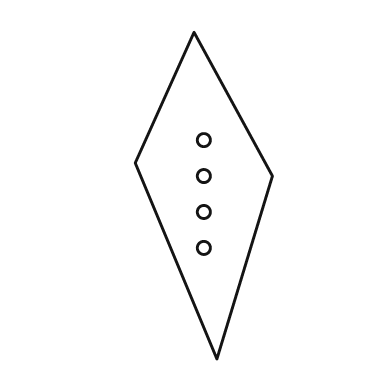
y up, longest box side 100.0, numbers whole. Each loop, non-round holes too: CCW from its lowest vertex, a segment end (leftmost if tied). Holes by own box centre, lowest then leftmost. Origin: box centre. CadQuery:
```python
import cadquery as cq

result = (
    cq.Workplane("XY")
    .moveTo(4.0, -50.0)
    .lineTo(21.0, 6.0)
    .lineTo(-3.0, 50.0)
    .lineTo(-21.0, 10.0)
    .close()
    .moveTo(0.0, -16.0)
    .circle(2.0)
    .moveTo(0.0, -5.0)
    .circle(2.0)
    .moveTo(0.0, 6.0)
    .circle(2.0)
    .moveTo(0.0, 17.0)
    .circle(2.0)
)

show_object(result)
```